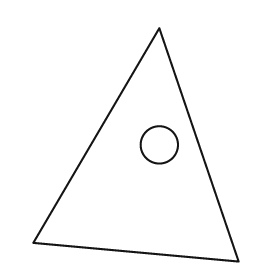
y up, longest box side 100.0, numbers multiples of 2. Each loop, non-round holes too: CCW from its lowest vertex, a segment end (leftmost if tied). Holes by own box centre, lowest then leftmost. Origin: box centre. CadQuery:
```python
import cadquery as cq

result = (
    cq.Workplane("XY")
    .moveTo(44.0, -50.0)
    .lineTo(10.0, 50.0)
    .lineTo(-44.0, -42.0)
    .close()
    .moveTo(10.0, 0.0)
    .circle(8.0)
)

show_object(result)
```